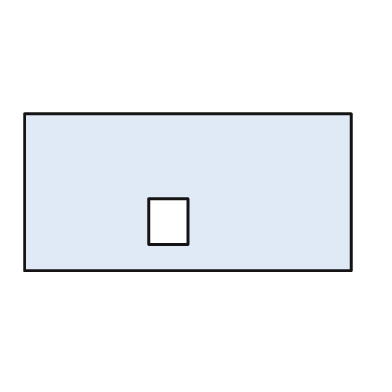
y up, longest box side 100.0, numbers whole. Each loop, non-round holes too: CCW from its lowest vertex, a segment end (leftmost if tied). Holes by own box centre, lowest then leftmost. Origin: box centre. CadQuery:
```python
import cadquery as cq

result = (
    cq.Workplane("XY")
    .moveTo(-50.0, -24.0)
    .lineTo(50.0, -24.0)
    .lineTo(50.0, 24.0)
    .lineTo(-50.0, 24.0)
    .close()
    .moveTo(-12.0, -16.0)
    .lineTo(0.0, -16.0)
    .lineTo(0.0, -2.0)
    .lineTo(-12.0, -2.0)
    .close()
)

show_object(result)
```